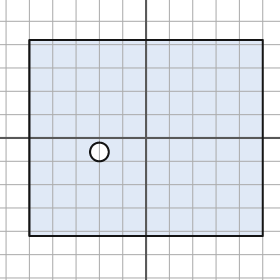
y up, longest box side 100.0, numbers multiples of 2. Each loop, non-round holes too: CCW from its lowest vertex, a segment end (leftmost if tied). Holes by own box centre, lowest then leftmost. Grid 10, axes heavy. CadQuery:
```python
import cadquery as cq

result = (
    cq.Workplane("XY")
    .moveTo(-50.0, -42.0)
    .lineTo(50.0, -42.0)
    .lineTo(50.0, 42.0)
    .lineTo(-50.0, 42.0)
    .close()
    .moveTo(-20.0, -6.0)
    .circle(4.0)
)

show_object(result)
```